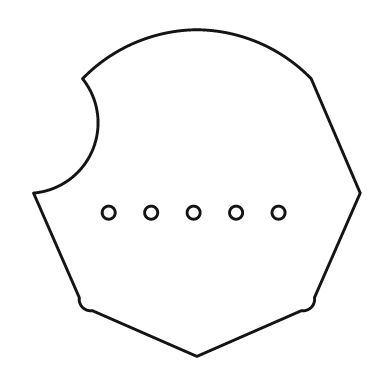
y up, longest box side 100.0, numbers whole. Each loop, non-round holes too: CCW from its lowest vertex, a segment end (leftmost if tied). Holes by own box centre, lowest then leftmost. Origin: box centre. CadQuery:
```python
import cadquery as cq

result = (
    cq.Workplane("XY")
    .moveTo(0.0, -50.0)
    .lineTo(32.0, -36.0)
    .threePointArc((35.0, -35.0), (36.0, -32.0))
    .lineTo(50.0, 0.0)
    .lineTo(35.0, 35.0)
    .threePointArc((19.0, 46.0), (0.0, 50.0))
    .threePointArc((-19.0, 46.0), (-35.0, 35.0))
    .threePointArc((-32.0, 13.0), (-50.0, 0.0))
    .lineTo(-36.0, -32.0)
    .threePointArc((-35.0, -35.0), (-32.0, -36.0))
    .close()
    .moveTo(-27.0, -6.0)
    .circle(2.0)
    .moveTo(-14.0, -6.0)
    .circle(2.0)
    .moveTo(-1.0, -6.0)
    .circle(2.0)
    .moveTo(12.0, -6.0)
    .circle(2.0)
    .moveTo(25.0, -6.0)
    .circle(2.0)
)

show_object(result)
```